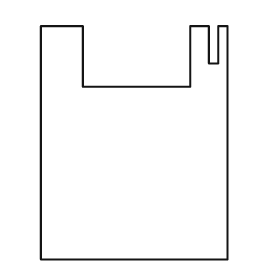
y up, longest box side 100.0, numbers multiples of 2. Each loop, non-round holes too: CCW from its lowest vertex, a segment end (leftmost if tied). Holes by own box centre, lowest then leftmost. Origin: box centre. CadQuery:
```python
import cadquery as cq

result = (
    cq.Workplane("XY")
    .moveTo(-40.0, -50.0)
    .lineTo(40.0, -50.0)
    .lineTo(40.0, 50.0)
    .lineTo(36.0, 50.0)
    .lineTo(36.0, 34.0)
    .lineTo(32.0, 34.0)
    .lineTo(32.0, 50.0)
    .lineTo(24.0, 50.0)
    .lineTo(24.0, 24.0)
    .lineTo(-22.0, 24.0)
    .lineTo(-22.0, 50.0)
    .lineTo(-40.0, 50.0)
    .close()
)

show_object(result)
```